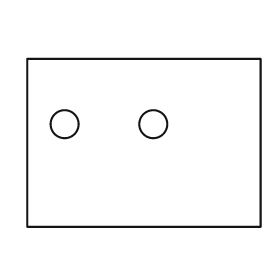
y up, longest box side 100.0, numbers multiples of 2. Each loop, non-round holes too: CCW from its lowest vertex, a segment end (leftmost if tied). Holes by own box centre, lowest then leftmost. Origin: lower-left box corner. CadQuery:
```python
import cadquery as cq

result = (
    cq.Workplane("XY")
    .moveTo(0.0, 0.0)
    .lineTo(100.0, 0.0)
    .lineTo(100.0, 72.0)
    .lineTo(0.0, 72.0)
    .close()
    .moveTo(16.0, 44.0)
    .circle(6.0)
    .moveTo(54.0, 44.0)
    .circle(6.0)
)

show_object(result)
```